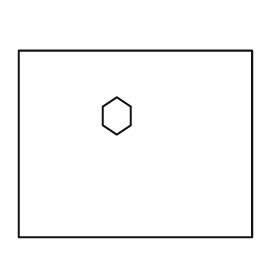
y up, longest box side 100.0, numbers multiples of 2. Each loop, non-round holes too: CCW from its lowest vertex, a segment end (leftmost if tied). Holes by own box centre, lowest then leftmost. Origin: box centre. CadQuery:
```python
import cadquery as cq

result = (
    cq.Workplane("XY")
    .moveTo(-50.0, -40.0)
    .lineTo(50.0, -40.0)
    .lineTo(50.0, 40.0)
    .lineTo(-50.0, 40.0)
    .close()
    .moveTo(-8.0, 4.0)
    .lineTo(-2.0, 8.0)
    .lineTo(-2.0, 16.0)
    .lineTo(-8.0, 20.0)
    .lineTo(-14.0, 16.0)
    .lineTo(-14.0, 8.0)
    .close()
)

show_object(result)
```